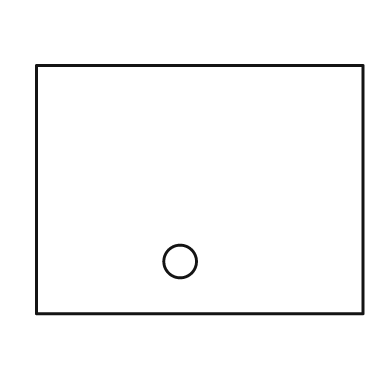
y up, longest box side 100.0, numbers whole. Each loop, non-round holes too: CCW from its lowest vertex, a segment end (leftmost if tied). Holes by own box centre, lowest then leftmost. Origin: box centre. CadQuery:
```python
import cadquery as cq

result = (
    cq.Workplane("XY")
    .moveTo(-50.0, -38.0)
    .lineTo(50.0, -38.0)
    .lineTo(50.0, 38.0)
    .lineTo(-50.0, 38.0)
    .close()
    .moveTo(-6.0, -22.0)
    .circle(5.0)
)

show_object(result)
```